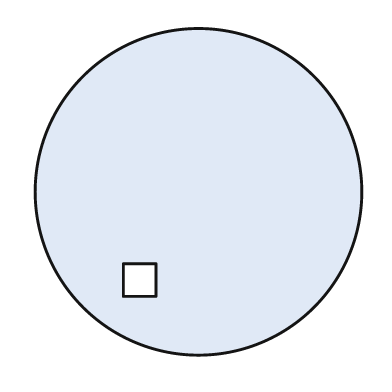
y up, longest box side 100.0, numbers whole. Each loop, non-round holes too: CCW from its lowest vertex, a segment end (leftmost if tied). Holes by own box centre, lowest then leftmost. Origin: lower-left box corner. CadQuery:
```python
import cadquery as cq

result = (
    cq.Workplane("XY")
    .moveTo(50.0, 50.0)
    .circle(50.0)
    .moveTo(27.0, 18.0)
    .lineTo(37.0, 18.0)
    .lineTo(37.0, 28.0)
    .lineTo(27.0, 28.0)
    .close()
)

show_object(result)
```